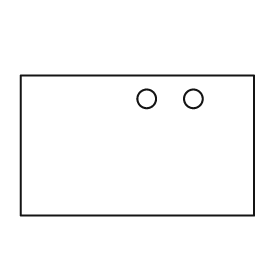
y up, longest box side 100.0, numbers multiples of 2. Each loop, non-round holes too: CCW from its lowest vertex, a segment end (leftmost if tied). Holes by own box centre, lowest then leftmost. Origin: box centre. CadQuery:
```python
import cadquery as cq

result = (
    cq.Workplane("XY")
    .moveTo(-50.0, -30.0)
    .lineTo(50.0, -30.0)
    .lineTo(50.0, 30.0)
    .lineTo(-50.0, 30.0)
    .close()
    .moveTo(4.0, 20.0)
    .circle(4.0)
    .moveTo(24.0, 20.0)
    .circle(4.0)
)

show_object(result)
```